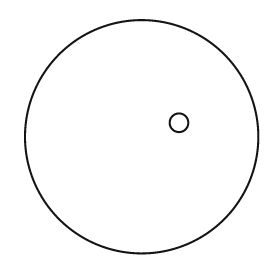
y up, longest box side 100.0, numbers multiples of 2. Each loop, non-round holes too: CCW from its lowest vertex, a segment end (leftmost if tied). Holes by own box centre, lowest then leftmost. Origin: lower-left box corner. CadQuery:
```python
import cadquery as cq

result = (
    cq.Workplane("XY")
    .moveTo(50.0, 50.0)
    .circle(50.0)
    .moveTo(66.0, 56.0)
    .circle(4.0)
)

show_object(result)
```